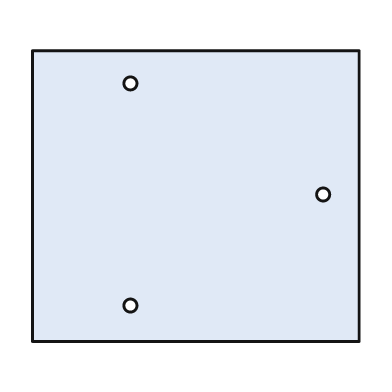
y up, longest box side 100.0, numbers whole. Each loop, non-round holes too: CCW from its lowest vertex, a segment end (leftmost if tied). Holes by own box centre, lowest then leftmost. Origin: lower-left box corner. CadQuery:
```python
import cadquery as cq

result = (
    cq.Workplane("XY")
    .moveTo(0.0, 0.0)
    .lineTo(100.0, 0.0)
    .lineTo(100.0, 89.0)
    .lineTo(0.0, 89.0)
    .close()
    .moveTo(30.0, 11.0)
    .circle(2.0)
    .moveTo(89.0, 45.0)
    .circle(2.0)
    .moveTo(30.0, 79.0)
    .circle(2.0)
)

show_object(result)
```